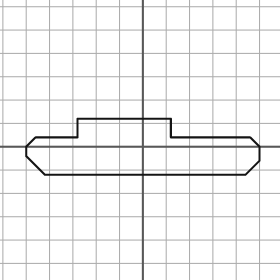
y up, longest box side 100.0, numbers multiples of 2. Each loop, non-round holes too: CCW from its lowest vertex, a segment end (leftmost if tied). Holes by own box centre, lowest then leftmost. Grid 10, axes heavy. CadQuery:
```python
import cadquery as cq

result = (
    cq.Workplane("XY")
    .moveTo(-42.0, -12.0)
    .lineTo(44.0, -12.0)
    .lineTo(50.0, -6.0)
    .lineTo(50.0, 0.0)
    .lineTo(46.0, 4.0)
    .lineTo(12.0, 4.0)
    .lineTo(12.0, 12.0)
    .lineTo(-28.0, 12.0)
    .lineTo(-28.0, 4.0)
    .lineTo(-46.0, 4.0)
    .lineTo(-50.0, 0.0)
    .lineTo(-50.0, -4.0)
    .close()
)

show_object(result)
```